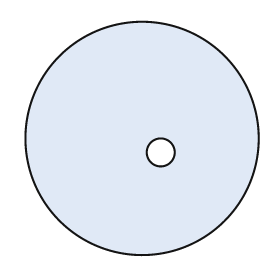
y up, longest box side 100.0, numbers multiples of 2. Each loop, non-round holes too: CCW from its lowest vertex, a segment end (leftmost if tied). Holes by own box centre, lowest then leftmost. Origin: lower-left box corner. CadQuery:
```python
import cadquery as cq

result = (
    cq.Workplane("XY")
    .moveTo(50.0, 50.0)
    .circle(50.0)
    .moveTo(58.0, 44.0)
    .circle(6.0)
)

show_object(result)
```